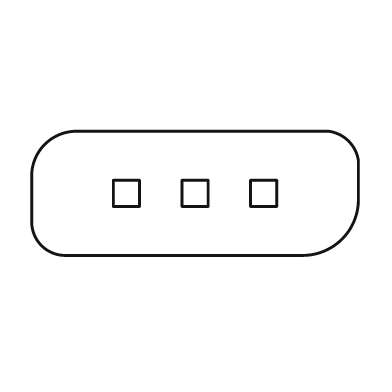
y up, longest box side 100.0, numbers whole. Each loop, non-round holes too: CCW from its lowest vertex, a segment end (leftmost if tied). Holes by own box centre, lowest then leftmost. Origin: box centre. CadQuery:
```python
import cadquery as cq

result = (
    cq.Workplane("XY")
    .moveTo(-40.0, -19.0)
    .lineTo(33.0, -19.0)
    .threePointArc((45.0, -14.0), (50.0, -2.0))
    .lineTo(50.0, 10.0)
    .threePointArc((47.0, 16.0), (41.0, 19.0))
    .lineTo(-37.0, 19.0)
    .threePointArc((-46.0, 15.0), (-50.0, 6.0))
    .lineTo(-50.0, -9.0)
    .threePointArc((-47.0, -16.0), (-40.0, -19.0))
    .close()
    .moveTo(-25.0, -4.0)
    .lineTo(-17.0, -4.0)
    .lineTo(-17.0, 4.0)
    .lineTo(-25.0, 4.0)
    .close()
    .moveTo(-4.0, -4.0)
    .lineTo(4.0, -4.0)
    .lineTo(4.0, 4.0)
    .lineTo(-4.0, 4.0)
    .close()
    .moveTo(17.0, -4.0)
    .lineTo(25.0, -4.0)
    .lineTo(25.0, 4.0)
    .lineTo(17.0, 4.0)
    .close()
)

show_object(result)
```